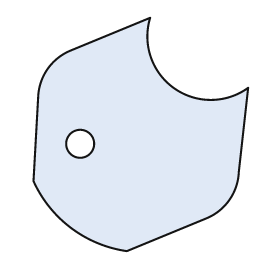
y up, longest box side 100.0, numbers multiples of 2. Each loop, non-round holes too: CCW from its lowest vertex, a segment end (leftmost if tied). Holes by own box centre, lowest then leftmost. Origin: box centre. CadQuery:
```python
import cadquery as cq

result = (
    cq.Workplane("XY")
    .moveTo(-6.0, -50.0)
    .lineTo(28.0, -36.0)
    .threePointArc((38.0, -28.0), (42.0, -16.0))
    .lineTo(46.0, 20.0)
    .threePointArc((14.0, 20.0), (4.0, 50.0))
    .lineTo(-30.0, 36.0)
    .threePointArc((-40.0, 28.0), (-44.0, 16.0))
    .lineTo(-46.0, -20.0)
    .threePointArc((-30.0, -40.0), (-6.0, -50.0))
    .close()
    .moveTo(-26.0, -4.0)
    .circle(6.0)
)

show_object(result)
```